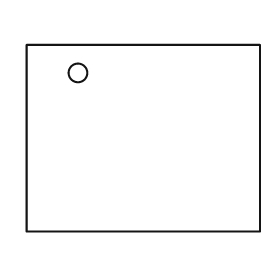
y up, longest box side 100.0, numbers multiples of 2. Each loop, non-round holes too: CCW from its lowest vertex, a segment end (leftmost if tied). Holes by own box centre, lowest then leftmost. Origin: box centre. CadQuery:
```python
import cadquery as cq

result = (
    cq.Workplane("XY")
    .moveTo(-50.0, -40.0)
    .lineTo(50.0, -40.0)
    .lineTo(50.0, 40.0)
    .lineTo(-50.0, 40.0)
    .close()
    .moveTo(-28.0, 28.0)
    .circle(4.0)
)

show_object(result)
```